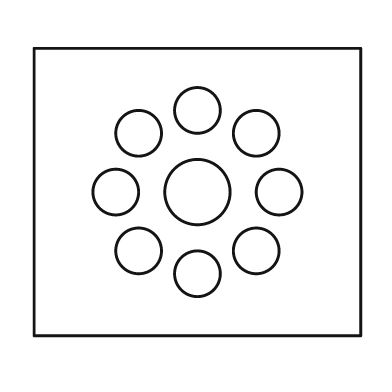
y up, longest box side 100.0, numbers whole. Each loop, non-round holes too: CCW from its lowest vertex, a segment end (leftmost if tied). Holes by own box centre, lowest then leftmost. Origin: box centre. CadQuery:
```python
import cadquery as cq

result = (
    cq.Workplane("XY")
    .moveTo(-50.0, -44.0)
    .lineTo(50.0, -44.0)
    .lineTo(50.0, 44.0)
    .lineTo(-50.0, 44.0)
    .close()
    .moveTo(0.0, -25.0)
    .circle(7.0)
    .moveTo(-18.0, -18.0)
    .circle(7.0)
    .moveTo(18.0, -18.0)
    .circle(7.0)
    .moveTo(-25.0, 0.0)
    .circle(7.0)
    .moveTo(0.0, 0.0)
    .circle(10.0)
    .moveTo(25.0, 0.0)
    .circle(7.0)
    .moveTo(-18.0, 18.0)
    .circle(7.0)
    .moveTo(18.0, 18.0)
    .circle(7.0)
    .moveTo(0.0, 25.0)
    .circle(7.0)
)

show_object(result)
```